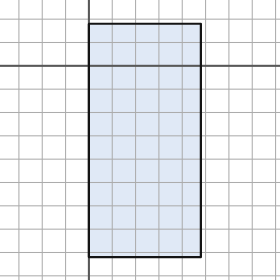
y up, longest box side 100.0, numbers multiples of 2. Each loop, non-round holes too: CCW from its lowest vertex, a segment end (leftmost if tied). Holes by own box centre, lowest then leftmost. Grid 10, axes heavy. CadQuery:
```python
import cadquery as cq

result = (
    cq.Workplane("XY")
    .moveTo(0.0, -82.0)
    .lineTo(48.0, -82.0)
    .lineTo(48.0, 18.0)
    .lineTo(0.0, 18.0)
    .close()
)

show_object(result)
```